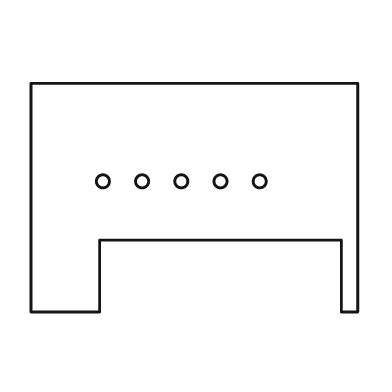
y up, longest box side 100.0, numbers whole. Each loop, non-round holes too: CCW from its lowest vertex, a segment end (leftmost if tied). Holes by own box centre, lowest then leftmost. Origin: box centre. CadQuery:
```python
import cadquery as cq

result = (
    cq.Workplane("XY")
    .moveTo(-50.0, -35.0)
    .lineTo(-29.0, -35.0)
    .lineTo(-29.0, -13.0)
    .lineTo(45.0, -13.0)
    .lineTo(45.0, -35.0)
    .lineTo(50.0, -35.0)
    .lineTo(50.0, 35.0)
    .lineTo(-50.0, 35.0)
    .close()
    .moveTo(-28.0, 5.0)
    .circle(2.0)
    .moveTo(-16.0, 5.0)
    .circle(2.0)
    .moveTo(-4.0, 5.0)
    .circle(2.0)
    .moveTo(8.0, 5.0)
    .circle(2.0)
    .moveTo(20.0, 5.0)
    .circle(2.0)
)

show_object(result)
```